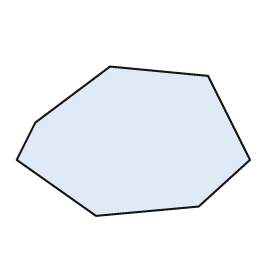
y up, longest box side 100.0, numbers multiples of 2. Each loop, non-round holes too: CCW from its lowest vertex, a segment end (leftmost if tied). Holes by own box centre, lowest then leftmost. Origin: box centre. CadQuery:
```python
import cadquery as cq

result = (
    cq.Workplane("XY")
    .moveTo(-16.0, -32.0)
    .lineTo(28.0, -28.0)
    .lineTo(50.0, -8.0)
    .lineTo(32.0, 28.0)
    .lineTo(-10.0, 32.0)
    .lineTo(-42.0, 8.0)
    .lineTo(-50.0, -8.0)
    .close()
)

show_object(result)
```